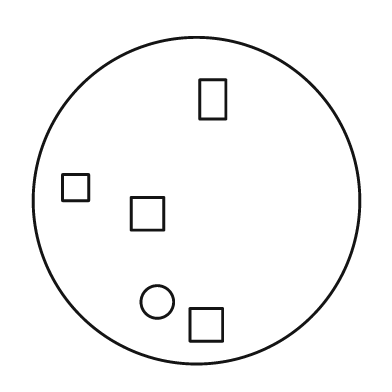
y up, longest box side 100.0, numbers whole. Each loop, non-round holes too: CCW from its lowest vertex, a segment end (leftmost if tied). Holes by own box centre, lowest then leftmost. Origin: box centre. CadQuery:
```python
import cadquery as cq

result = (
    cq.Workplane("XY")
    .moveTo(0.0, 0.0)
    .circle(50.0)
    .moveTo(-2.0, -43.0)
    .lineTo(8.0, -43.0)
    .lineTo(8.0, -33.0)
    .lineTo(-2.0, -33.0)
    .close()
    .moveTo(-12.0, -31.0)
    .circle(5.0)
    .moveTo(-20.0, -9.0)
    .lineTo(-10.0, -9.0)
    .lineTo(-10.0, 1.0)
    .lineTo(-20.0, 1.0)
    .close()
    .moveTo(-41.0, 0.0)
    .lineTo(-33.0, 0.0)
    .lineTo(-33.0, 8.0)
    .lineTo(-41.0, 8.0)
    .close()
    .moveTo(1.0, 25.0)
    .lineTo(9.0, 25.0)
    .lineTo(9.0, 37.0)
    .lineTo(1.0, 37.0)
    .close()
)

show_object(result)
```